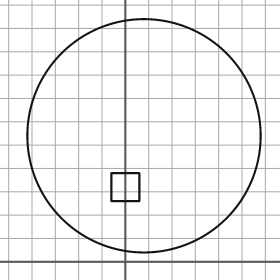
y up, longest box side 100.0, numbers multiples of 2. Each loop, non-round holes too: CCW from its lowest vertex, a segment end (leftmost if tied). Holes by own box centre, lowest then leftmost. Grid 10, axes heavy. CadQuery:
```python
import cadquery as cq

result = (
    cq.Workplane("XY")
    .moveTo(8.0, 54.0)
    .circle(50.0)
    .moveTo(-6.0, 26.0)
    .lineTo(6.0, 26.0)
    .lineTo(6.0, 38.0)
    .lineTo(-6.0, 38.0)
    .close()
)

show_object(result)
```